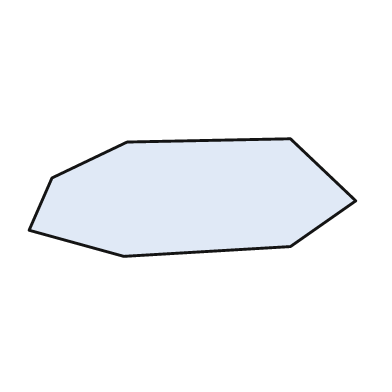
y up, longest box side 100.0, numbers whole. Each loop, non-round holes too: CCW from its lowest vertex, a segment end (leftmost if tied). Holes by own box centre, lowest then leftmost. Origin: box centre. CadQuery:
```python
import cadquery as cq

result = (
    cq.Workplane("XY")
    .moveTo(-21.0, -18.0)
    .lineTo(30.0, -15.0)
    .lineTo(50.0, -1.0)
    .lineTo(30.0, 18.0)
    .lineTo(-20.0, 17.0)
    .lineTo(-43.0, 6.0)
    .lineTo(-50.0, -10.0)
    .close()
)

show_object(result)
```